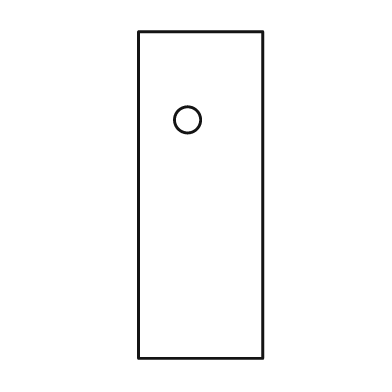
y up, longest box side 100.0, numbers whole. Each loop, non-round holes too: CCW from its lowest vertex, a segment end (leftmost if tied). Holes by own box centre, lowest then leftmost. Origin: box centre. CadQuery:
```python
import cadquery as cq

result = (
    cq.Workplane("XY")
    .moveTo(-19.0, -50.0)
    .lineTo(19.0, -50.0)
    .lineTo(19.0, 50.0)
    .lineTo(-19.0, 50.0)
    .close()
    .moveTo(-4.0, 23.0)
    .circle(4.0)
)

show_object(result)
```